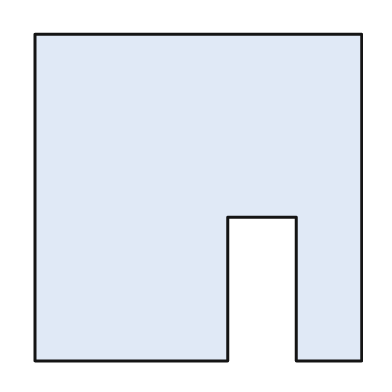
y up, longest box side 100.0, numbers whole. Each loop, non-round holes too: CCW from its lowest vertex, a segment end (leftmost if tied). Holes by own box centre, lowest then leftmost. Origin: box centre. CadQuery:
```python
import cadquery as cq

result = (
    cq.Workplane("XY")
    .moveTo(-50.0, -50.0)
    .lineTo(9.0, -50.0)
    .lineTo(9.0, -6.0)
    .lineTo(30.0, -6.0)
    .lineTo(30.0, -50.0)
    .lineTo(50.0, -50.0)
    .lineTo(50.0, 50.0)
    .lineTo(-50.0, 50.0)
    .close()
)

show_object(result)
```